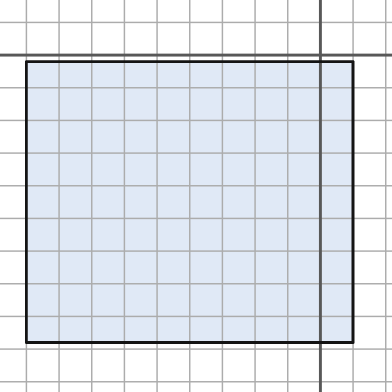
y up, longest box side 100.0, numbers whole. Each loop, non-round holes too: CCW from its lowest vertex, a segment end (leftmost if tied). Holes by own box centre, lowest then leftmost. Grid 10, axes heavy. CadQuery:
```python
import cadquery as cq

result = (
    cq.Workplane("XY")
    .moveTo(-90.0, -88.0)
    .lineTo(10.0, -88.0)
    .lineTo(10.0, -2.0)
    .lineTo(-90.0, -2.0)
    .close()
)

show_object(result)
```